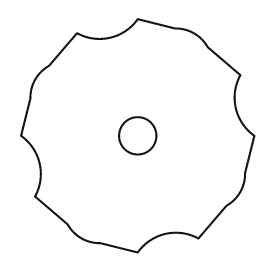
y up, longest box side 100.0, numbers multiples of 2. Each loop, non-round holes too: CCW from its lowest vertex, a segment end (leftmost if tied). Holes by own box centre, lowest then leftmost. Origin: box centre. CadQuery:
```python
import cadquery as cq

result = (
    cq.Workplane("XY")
    .moveTo(0.0, -50.0)
    .threePointArc((12.0, -42.0), (26.0, -44.0))
    .lineTo(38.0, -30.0)
    .threePointArc((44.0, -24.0), (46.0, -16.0))
    .lineTo(50.0, 0.0)
    .threePointArc((42.0, 12.0), (44.0, 26.0))
    .lineTo(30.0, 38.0)
    .threePointArc((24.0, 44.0), (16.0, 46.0))
    .lineTo(0.0, 50.0)
    .threePointArc((-12.0, 42.0), (-26.0, 44.0))
    .lineTo(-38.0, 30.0)
    .threePointArc((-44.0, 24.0), (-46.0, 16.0))
    .lineTo(-50.0, 0.0)
    .threePointArc((-42.0, -12.0), (-44.0, -26.0))
    .lineTo(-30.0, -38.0)
    .threePointArc((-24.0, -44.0), (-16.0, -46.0))
    .close()
    .moveTo(0.0, 0.0)
    .circle(8.0)
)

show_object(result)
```